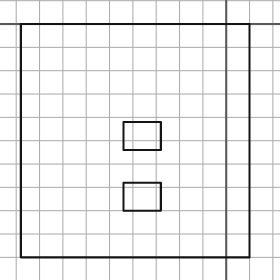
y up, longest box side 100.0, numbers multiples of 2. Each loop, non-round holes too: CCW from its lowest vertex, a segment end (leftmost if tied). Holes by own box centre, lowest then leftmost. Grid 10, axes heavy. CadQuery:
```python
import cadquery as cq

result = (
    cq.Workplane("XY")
    .moveTo(-88.0, -100.0)
    .lineTo(10.0, -100.0)
    .lineTo(10.0, 0.0)
    .lineTo(-88.0, 0.0)
    .close()
    .moveTo(-44.0, -80.0)
    .lineTo(-28.0, -80.0)
    .lineTo(-28.0, -68.0)
    .lineTo(-44.0, -68.0)
    .close()
    .moveTo(-44.0, -54.0)
    .lineTo(-28.0, -54.0)
    .lineTo(-28.0, -42.0)
    .lineTo(-44.0, -42.0)
    .close()
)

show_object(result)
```